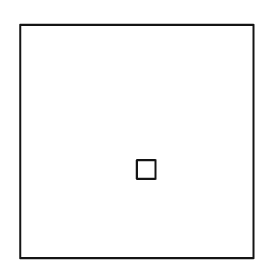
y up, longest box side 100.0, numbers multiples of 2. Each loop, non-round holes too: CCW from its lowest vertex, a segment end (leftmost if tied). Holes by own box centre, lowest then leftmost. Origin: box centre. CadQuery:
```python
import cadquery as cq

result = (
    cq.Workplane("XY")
    .moveTo(-50.0, -50.0)
    .lineTo(50.0, -50.0)
    .lineTo(50.0, 50.0)
    .lineTo(-50.0, 50.0)
    .close()
    .moveTo(0.0, -16.0)
    .lineTo(8.0, -16.0)
    .lineTo(8.0, -8.0)
    .lineTo(0.0, -8.0)
    .close()
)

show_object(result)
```